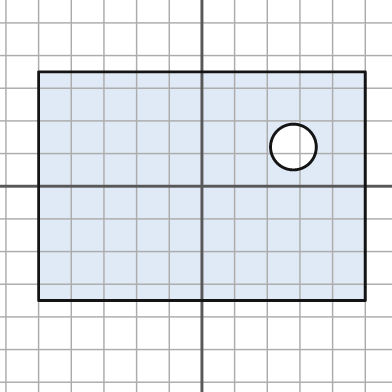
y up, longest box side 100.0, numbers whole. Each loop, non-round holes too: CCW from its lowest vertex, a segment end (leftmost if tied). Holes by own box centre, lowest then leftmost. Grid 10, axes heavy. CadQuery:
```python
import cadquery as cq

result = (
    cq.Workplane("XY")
    .moveTo(-50.0, -35.0)
    .lineTo(50.0, -35.0)
    .lineTo(50.0, 35.0)
    .lineTo(-50.0, 35.0)
    .close()
    .moveTo(28.0, 12.0)
    .circle(7.0)
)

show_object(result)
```